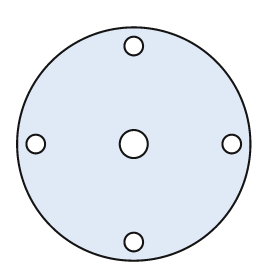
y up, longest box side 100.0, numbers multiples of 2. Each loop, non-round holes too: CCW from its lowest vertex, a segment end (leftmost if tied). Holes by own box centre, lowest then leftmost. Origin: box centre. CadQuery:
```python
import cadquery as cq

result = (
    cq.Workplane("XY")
    .moveTo(0.0, 0.0)
    .circle(50.0)
    .moveTo(0.0, -42.0)
    .circle(4.0)
    .moveTo(-42.0, 0.0)
    .circle(4.0)
    .moveTo(0.0, 0.0)
    .circle(6.0)
    .moveTo(42.0, 0.0)
    .circle(4.0)
    .moveTo(0.0, 42.0)
    .circle(4.0)
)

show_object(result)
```